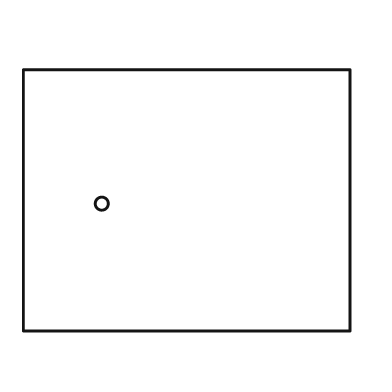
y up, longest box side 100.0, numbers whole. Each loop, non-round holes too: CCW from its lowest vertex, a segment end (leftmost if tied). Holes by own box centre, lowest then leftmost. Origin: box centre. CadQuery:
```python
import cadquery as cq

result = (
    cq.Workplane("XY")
    .moveTo(-50.0, -40.0)
    .lineTo(50.0, -40.0)
    .lineTo(50.0, 40.0)
    .lineTo(-50.0, 40.0)
    .close()
    .moveTo(-26.0, -1.0)
    .circle(2.0)
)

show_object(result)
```